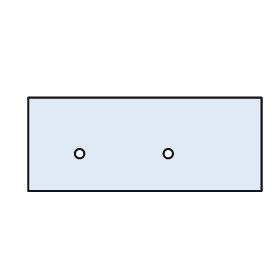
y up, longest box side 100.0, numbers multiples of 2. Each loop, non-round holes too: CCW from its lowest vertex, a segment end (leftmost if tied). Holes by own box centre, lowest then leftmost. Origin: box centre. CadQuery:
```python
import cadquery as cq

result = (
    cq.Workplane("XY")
    .moveTo(-50.0, -20.0)
    .lineTo(50.0, -20.0)
    .lineTo(50.0, 20.0)
    .lineTo(-50.0, 20.0)
    .close()
    .moveTo(-28.0, -4.0)
    .circle(2.0)
    .moveTo(10.0, -4.0)
    .circle(2.0)
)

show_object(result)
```